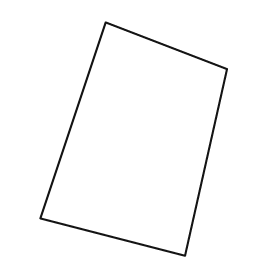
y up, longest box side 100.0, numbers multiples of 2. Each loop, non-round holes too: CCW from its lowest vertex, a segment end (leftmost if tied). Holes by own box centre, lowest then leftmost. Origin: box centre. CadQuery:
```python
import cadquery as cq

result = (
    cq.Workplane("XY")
    .moveTo(22.0, -50.0)
    .lineTo(40.0, 30.0)
    .lineTo(-12.0, 50.0)
    .lineTo(-40.0, -34.0)
    .close()
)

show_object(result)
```